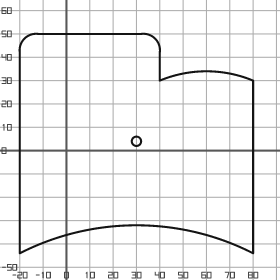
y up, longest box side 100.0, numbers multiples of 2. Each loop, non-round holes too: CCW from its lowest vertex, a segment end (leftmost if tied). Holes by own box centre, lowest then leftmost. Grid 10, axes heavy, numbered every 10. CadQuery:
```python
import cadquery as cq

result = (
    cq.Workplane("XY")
    .moveTo(-20.0, -44.0)
    .threePointArc((30.0, -32.0), (80.0, -44.0))
    .lineTo(80.0, 30.0)
    .threePointArc((60.0, 34.0), (40.0, 30.0))
    .lineTo(40.0, 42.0)
    .threePointArc((38.0, 48.0), (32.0, 50.0))
    .lineTo(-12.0, 50.0)
    .threePointArc((-18.0, 48.0), (-20.0, 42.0))
    .close()
    .moveTo(30.0, 4.0)
    .circle(2.0)
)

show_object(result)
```